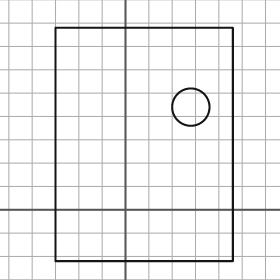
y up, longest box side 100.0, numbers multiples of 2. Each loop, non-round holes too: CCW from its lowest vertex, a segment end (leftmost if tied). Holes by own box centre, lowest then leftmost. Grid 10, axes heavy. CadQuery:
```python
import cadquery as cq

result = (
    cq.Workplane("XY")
    .moveTo(-30.0, -22.0)
    .lineTo(46.0, -22.0)
    .lineTo(46.0, 78.0)
    .lineTo(-30.0, 78.0)
    .close()
    .moveTo(28.0, 44.0)
    .circle(8.0)
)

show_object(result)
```